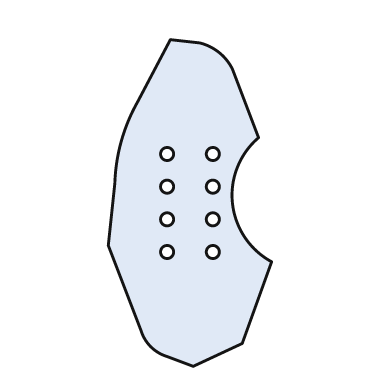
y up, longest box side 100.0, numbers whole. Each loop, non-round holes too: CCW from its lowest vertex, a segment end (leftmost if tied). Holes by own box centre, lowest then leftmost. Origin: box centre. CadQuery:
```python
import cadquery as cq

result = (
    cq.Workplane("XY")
    .moveTo(1.0, -50.0)
    .lineTo(16.0, -43.0)
    .lineTo(25.0, -18.0)
    .threePointArc((13.0, 0.0), (21.0, 20.0))
    .lineTo(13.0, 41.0)
    .threePointArc((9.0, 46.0), (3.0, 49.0))
    .lineTo(-6.0, 50.0)
    .lineTo(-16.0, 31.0)
    .threePointArc((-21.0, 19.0), (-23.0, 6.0))
    .lineTo(-25.0, -13.0)
    .lineTo(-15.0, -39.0)
    .threePointArc((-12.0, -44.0), (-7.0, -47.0))
    .close()
    .moveTo(-7.0, -15.0)
    .circle(2.0)
    .moveTo(7.0, -15.0)
    .circle(2.0)
    .moveTo(-7.0, -5.0)
    .circle(2.0)
    .moveTo(7.0, -5.0)
    .circle(2.0)
    .moveTo(-7.0, 5.0)
    .circle(2.0)
    .moveTo(7.0, 5.0)
    .circle(2.0)
    .moveTo(-7.0, 15.0)
    .circle(2.0)
    .moveTo(7.0, 15.0)
    .circle(2.0)
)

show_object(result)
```